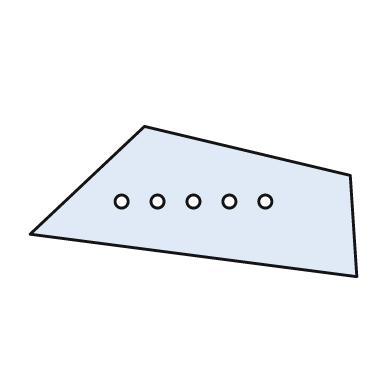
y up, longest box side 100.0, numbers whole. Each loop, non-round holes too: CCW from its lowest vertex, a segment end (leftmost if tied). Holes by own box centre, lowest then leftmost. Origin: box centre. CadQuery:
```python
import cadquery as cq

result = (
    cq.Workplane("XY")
    .moveTo(50.0, -23.0)
    .lineTo(48.0, 8.0)
    .lineTo(-15.0, 23.0)
    .lineTo(-50.0, -10.0)
    .close()
    .moveTo(-22.0, 0.0)
    .circle(2.0)
    .moveTo(-11.0, 0.0)
    .circle(2.0)
    .moveTo(0.0, 0.0)
    .circle(2.0)
    .moveTo(11.0, 0.0)
    .circle(2.0)
    .moveTo(22.0, 0.0)
    .circle(2.0)
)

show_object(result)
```